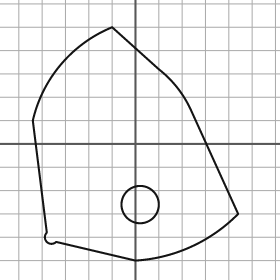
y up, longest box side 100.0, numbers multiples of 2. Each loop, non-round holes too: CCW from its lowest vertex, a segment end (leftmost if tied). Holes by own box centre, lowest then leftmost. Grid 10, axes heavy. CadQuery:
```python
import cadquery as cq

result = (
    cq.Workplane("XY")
    .moveTo(0.0, -50.0)
    .threePointArc((24.0, -44.0), (44.0, -30.0))
    .lineTo(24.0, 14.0)
    .threePointArc((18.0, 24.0), (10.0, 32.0))
    .lineTo(-10.0, 50.0)
    .threePointArc((-32.0, 34.0), (-44.0, 10.0))
    .lineTo(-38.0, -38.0)
    .threePointArc((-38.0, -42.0), (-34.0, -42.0))
    .close()
    .moveTo(2.0, -26.0)
    .circle(8.0)
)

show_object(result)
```